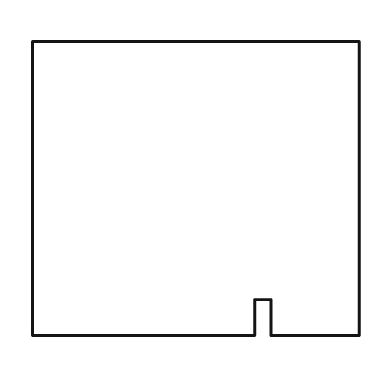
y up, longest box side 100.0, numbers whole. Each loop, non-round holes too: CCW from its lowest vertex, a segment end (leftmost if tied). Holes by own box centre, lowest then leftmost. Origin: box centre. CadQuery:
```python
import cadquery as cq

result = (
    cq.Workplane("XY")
    .moveTo(-50.0, -45.0)
    .lineTo(18.0, -45.0)
    .lineTo(18.0, -34.0)
    .lineTo(23.0, -34.0)
    .lineTo(23.0, -45.0)
    .lineTo(50.0, -45.0)
    .lineTo(50.0, 45.0)
    .lineTo(-50.0, 45.0)
    .close()
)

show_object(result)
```